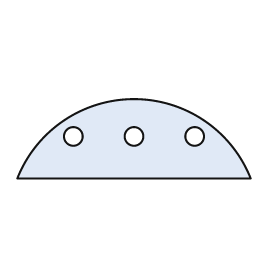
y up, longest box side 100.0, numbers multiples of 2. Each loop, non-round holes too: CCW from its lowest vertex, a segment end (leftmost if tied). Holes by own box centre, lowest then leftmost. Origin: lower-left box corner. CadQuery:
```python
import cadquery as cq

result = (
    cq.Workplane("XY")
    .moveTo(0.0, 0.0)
    .lineTo(100.0, 0.0)
    .threePointArc((50.0, 34.0), (0.0, 0.0))
    .close()
    .moveTo(24.0, 18.0)
    .circle(4.0)
    .moveTo(50.0, 18.0)
    .circle(4.0)
    .moveTo(76.0, 18.0)
    .circle(4.0)
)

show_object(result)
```